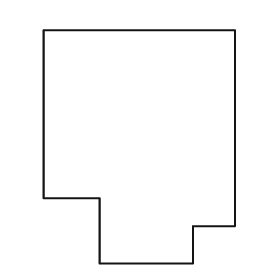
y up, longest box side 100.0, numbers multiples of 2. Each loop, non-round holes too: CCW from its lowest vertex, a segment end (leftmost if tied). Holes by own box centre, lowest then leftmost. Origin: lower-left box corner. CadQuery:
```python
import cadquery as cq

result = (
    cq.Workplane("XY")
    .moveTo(24.0, 0.0)
    .lineTo(64.0, 0.0)
    .lineTo(64.0, 16.0)
    .lineTo(82.0, 16.0)
    .lineTo(82.0, 100.0)
    .lineTo(0.0, 100.0)
    .lineTo(0.0, 28.0)
    .lineTo(24.0, 28.0)
    .close()
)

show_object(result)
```